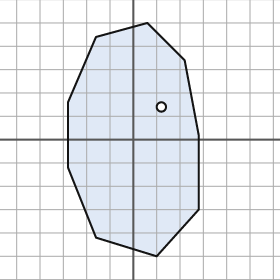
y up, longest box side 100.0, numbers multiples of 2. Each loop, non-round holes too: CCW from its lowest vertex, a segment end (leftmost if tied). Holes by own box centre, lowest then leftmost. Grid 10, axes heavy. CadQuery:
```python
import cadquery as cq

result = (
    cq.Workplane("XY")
    .moveTo(10.0, -50.0)
    .lineTo(28.0, -30.0)
    .lineTo(28.0, 2.0)
    .lineTo(22.0, 34.0)
    .lineTo(6.0, 50.0)
    .lineTo(-16.0, 44.0)
    .lineTo(-28.0, 16.0)
    .lineTo(-28.0, -12.0)
    .lineTo(-16.0, -42.0)
    .close()
    .moveTo(12.0, 14.0)
    .circle(2.0)
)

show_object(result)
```